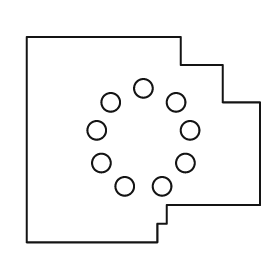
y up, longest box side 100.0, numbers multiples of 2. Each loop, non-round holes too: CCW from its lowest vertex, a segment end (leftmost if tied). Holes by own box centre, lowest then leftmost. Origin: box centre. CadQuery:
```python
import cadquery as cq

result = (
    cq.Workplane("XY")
    .moveTo(-50.0, -44.0)
    .lineTo(6.0, -44.0)
    .lineTo(6.0, -36.0)
    .lineTo(10.0, -36.0)
    .lineTo(10.0, -28.0)
    .lineTo(50.0, -28.0)
    .lineTo(50.0, 16.0)
    .lineTo(34.0, 16.0)
    .lineTo(34.0, 32.0)
    .lineTo(16.0, 32.0)
    .lineTo(16.0, 44.0)
    .lineTo(-50.0, 44.0)
    .close()
    .moveTo(-8.0, -20.0)
    .circle(4.0)
    .moveTo(8.0, -20.0)
    .circle(4.0)
    .moveTo(-18.0, -10.0)
    .circle(4.0)
    .moveTo(18.0, -10.0)
    .circle(4.0)
    .moveTo(-20.0, 4.0)
    .circle(4.0)
    .moveTo(20.0, 4.0)
    .circle(4.0)
    .moveTo(-14.0, 16.0)
    .circle(4.0)
    .moveTo(14.0, 16.0)
    .circle(4.0)
    .moveTo(0.0, 22.0)
    .circle(4.0)
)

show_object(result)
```